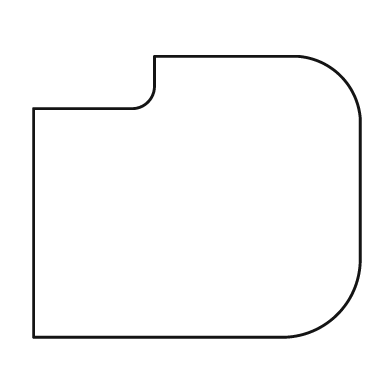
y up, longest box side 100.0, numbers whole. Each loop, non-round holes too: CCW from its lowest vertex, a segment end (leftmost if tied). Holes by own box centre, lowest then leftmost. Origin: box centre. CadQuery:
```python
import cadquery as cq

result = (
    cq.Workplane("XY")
    .moveTo(-50.0, -43.0)
    .lineTo(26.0, -43.0)
    .threePointArc((43.0, -36.0), (50.0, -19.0))
    .lineTo(50.0, 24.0)
    .threePointArc((44.0, 37.0), (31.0, 43.0))
    .lineTo(-13.0, 43.0)
    .lineTo(-13.0, 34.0)
    .threePointArc((-15.0, 29.0), (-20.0, 27.0))
    .lineTo(-50.0, 27.0)
    .close()
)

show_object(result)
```